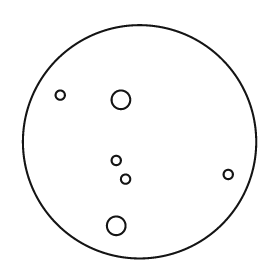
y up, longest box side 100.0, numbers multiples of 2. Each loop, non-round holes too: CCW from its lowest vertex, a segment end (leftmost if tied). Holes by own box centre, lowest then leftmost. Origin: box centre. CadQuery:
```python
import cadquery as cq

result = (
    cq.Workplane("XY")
    .moveTo(0.0, 0.0)
    .circle(50.0)
    .moveTo(-10.0, -36.0)
    .circle(4.0)
    .moveTo(-6.0, -16.0)
    .circle(2.0)
    .moveTo(38.0, -14.0)
    .circle(2.0)
    .moveTo(-10.0, -8.0)
    .circle(2.0)
    .moveTo(-8.0, 18.0)
    .circle(4.0)
    .moveTo(-34.0, 20.0)
    .circle(2.0)
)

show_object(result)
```